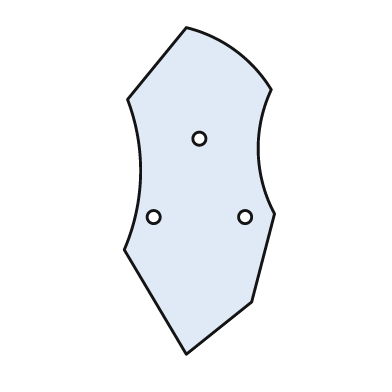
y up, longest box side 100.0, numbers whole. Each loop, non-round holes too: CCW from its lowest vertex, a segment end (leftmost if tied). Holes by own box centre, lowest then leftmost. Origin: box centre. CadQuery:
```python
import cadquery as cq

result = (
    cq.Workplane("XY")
    .moveTo(-4.0, -50.0)
    .lineTo(16.0, -34.0)
    .lineTo(23.0, -7.0)
    .threePointArc((18.0, 12.0), (22.0, 31.0))
    .threePointArc((11.0, 43.0), (-4.0, 50.0))
    .lineTo(-22.0, 28.0)
    .threePointArc((-18.0, 5.0), (-23.0, -18.0))
    .close()
    .moveTo(-14.0, -8.0)
    .circle(2.0)
    .moveTo(14.0, -8.0)
    .circle(2.0)
    .moveTo(0.0, 16.0)
    .circle(2.0)
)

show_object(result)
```